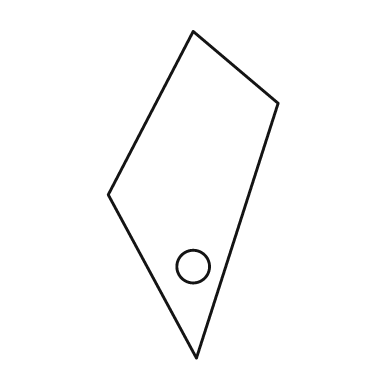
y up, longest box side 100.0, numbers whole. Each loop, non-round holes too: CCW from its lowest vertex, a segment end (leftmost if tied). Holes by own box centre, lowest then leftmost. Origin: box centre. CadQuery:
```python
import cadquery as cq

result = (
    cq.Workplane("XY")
    .moveTo(1.0, -50.0)
    .lineTo(26.0, 28.0)
    .lineTo(0.0, 50.0)
    .lineTo(-26.0, 0.0)
    .close()
    .moveTo(0.0, -22.0)
    .circle(5.0)
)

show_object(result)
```